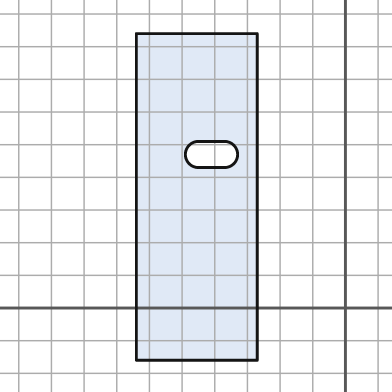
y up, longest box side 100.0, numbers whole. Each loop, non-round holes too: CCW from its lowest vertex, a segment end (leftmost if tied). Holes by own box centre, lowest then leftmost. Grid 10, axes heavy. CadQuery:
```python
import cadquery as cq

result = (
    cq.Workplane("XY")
    .moveTo(-64.0, -16.0)
    .lineTo(-27.0, -16.0)
    .lineTo(-27.0, 84.0)
    .lineTo(-64.0, 84.0)
    .close()
    .moveTo(-45.0, 43.0)
    .lineTo(-37.0, 43.0)
    .threePointArc((-33.0, 47.0), (-37.0, 51.0))
    .lineTo(-45.0, 51.0)
    .threePointArc((-49.0, 47.0), (-45.0, 43.0))
    .close()
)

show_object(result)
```